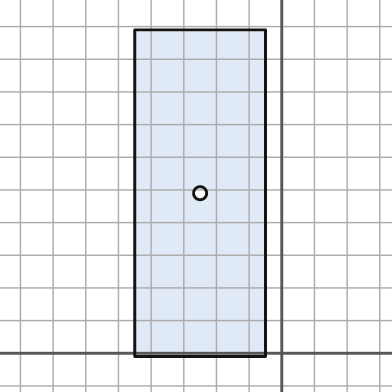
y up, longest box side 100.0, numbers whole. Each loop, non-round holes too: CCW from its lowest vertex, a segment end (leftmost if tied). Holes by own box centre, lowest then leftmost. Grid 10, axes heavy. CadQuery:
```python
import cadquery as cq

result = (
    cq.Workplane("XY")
    .moveTo(-45.0, -1.0)
    .lineTo(-5.0, -1.0)
    .lineTo(-5.0, 99.0)
    .lineTo(-45.0, 99.0)
    .close()
    .moveTo(-25.0, 49.0)
    .circle(2.0)
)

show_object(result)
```